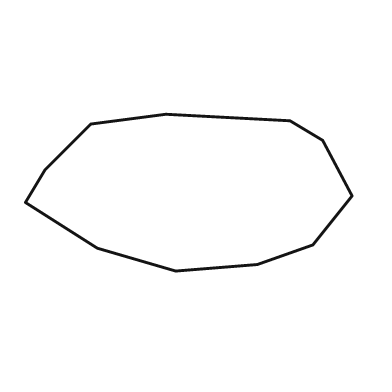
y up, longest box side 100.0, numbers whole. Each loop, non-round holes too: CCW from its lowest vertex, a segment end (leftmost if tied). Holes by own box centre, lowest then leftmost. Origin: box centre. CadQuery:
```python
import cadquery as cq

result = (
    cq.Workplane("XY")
    .moveTo(-4.0, -24.0)
    .lineTo(21.0, -22.0)
    .lineTo(38.0, -16.0)
    .lineTo(50.0, -1.0)
    .lineTo(41.0, 16.0)
    .lineTo(31.0, 22.0)
    .lineTo(-7.0, 24.0)
    .lineTo(-30.0, 21.0)
    .lineTo(-44.0, 7.0)
    .lineTo(-50.0, -3.0)
    .lineTo(-28.0, -17.0)
    .close()
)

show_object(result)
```